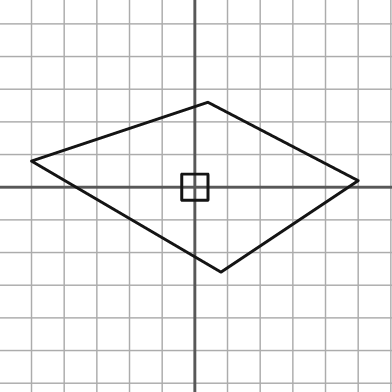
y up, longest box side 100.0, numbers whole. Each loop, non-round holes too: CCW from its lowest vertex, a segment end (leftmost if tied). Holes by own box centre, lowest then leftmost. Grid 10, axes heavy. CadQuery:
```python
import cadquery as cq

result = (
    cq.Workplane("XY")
    .moveTo(8.0, -26.0)
    .lineTo(50.0, 2.0)
    .lineTo(4.0, 26.0)
    .lineTo(-50.0, 8.0)
    .close()
    .moveTo(-4.0, -4.0)
    .lineTo(4.0, -4.0)
    .lineTo(4.0, 4.0)
    .lineTo(-4.0, 4.0)
    .close()
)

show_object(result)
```